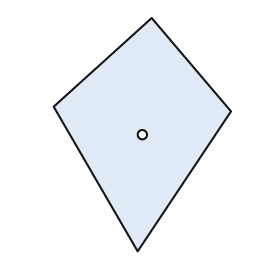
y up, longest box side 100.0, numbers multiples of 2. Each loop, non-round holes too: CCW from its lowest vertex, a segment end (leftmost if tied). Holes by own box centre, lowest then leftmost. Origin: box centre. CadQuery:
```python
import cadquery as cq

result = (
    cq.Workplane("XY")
    .moveTo(-2.0, -50.0)
    .lineTo(38.0, 10.0)
    .lineTo(4.0, 50.0)
    .lineTo(-38.0, 12.0)
    .close()
    .moveTo(0.0, 0.0)
    .circle(2.0)
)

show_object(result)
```